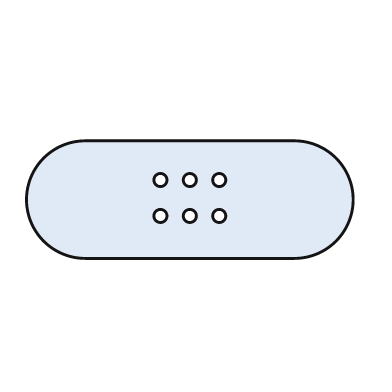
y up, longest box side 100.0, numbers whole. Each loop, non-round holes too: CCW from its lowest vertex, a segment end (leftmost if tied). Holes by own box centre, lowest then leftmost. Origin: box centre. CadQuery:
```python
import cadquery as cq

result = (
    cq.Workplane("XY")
    .moveTo(-32.0, -18.0)
    .lineTo(32.0, -18.0)
    .threePointArc((50.0, 0.0), (32.0, 18.0))
    .lineTo(-32.0, 18.0)
    .threePointArc((-50.0, 0.0), (-32.0, -18.0))
    .close()
    .moveTo(-9.0, -5.0)
    .circle(2.0)
    .moveTo(0.0, -5.0)
    .circle(2.0)
    .moveTo(9.0, -5.0)
    .circle(2.0)
    .moveTo(-9.0, 6.0)
    .circle(2.0)
    .moveTo(0.0, 6.0)
    .circle(2.0)
    .moveTo(9.0, 6.0)
    .circle(2.0)
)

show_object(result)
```